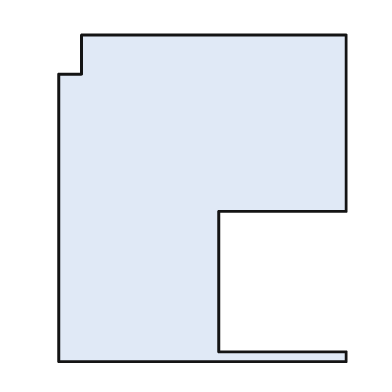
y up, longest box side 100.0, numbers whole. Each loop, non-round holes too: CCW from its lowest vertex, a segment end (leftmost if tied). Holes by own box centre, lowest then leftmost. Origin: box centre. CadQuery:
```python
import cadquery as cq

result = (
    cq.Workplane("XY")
    .moveTo(-44.0, -50.0)
    .lineTo(44.0, -50.0)
    .lineTo(44.0, -47.0)
    .lineTo(5.0, -47.0)
    .lineTo(5.0, -4.0)
    .lineTo(44.0, -4.0)
    .lineTo(44.0, 50.0)
    .lineTo(-37.0, 50.0)
    .lineTo(-37.0, 38.0)
    .lineTo(-44.0, 38.0)
    .close()
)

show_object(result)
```